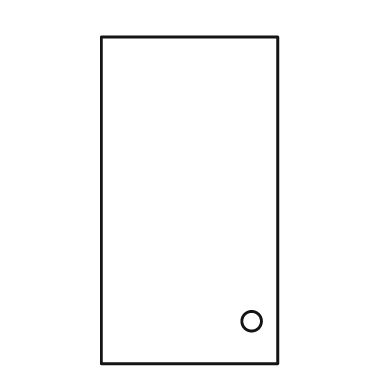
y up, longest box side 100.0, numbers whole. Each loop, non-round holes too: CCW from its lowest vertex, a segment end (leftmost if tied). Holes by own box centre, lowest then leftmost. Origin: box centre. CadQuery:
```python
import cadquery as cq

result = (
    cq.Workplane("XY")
    .moveTo(-27.0, -50.0)
    .lineTo(27.0, -50.0)
    .lineTo(27.0, 50.0)
    .lineTo(-27.0, 50.0)
    .close()
    .moveTo(19.0, -37.0)
    .circle(3.0)
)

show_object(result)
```